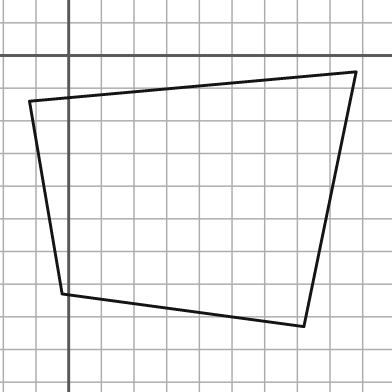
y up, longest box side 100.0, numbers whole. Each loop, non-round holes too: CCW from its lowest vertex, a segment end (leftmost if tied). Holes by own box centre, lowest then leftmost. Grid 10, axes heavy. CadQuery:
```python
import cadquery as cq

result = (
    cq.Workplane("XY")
    .moveTo(72.0, -83.0)
    .lineTo(88.0, -5.0)
    .lineTo(-12.0, -14.0)
    .lineTo(-2.0, -73.0)
    .close()
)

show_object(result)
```